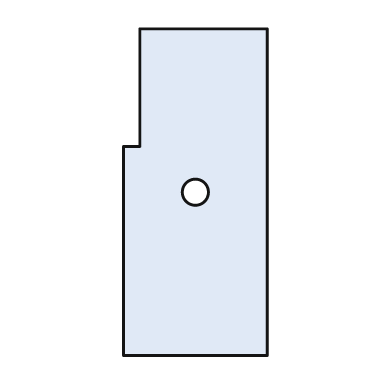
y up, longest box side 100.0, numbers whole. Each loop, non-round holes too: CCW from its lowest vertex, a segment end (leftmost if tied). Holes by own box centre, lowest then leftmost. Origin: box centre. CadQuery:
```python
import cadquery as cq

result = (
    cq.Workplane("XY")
    .moveTo(-22.0, -50.0)
    .lineTo(22.0, -50.0)
    .lineTo(22.0, 50.0)
    .lineTo(-17.0, 50.0)
    .lineTo(-17.0, 14.0)
    .lineTo(-22.0, 14.0)
    .close()
    .moveTo(0.0, 0.0)
    .circle(4.0)
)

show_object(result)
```